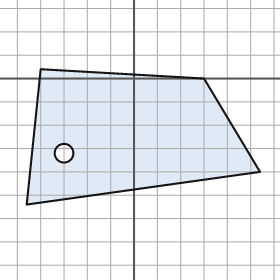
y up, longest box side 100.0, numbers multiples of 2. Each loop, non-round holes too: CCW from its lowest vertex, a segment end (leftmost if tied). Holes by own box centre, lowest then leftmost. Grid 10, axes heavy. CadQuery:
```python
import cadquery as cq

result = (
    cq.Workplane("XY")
    .moveTo(-46.0, -54.0)
    .lineTo(54.0, -40.0)
    .lineTo(30.0, 0.0)
    .lineTo(-40.0, 4.0)
    .close()
    .moveTo(-30.0, -32.0)
    .circle(4.0)
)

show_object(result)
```